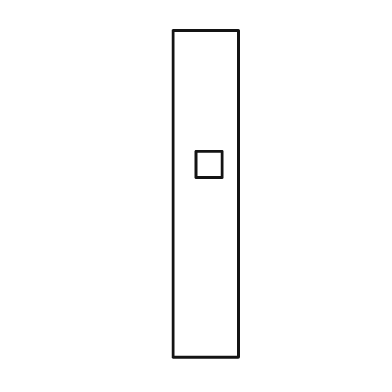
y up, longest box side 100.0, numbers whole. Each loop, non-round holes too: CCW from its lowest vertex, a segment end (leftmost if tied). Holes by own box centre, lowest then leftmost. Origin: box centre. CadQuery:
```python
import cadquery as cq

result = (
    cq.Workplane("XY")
    .moveTo(-10.0, -50.0)
    .lineTo(10.0, -50.0)
    .lineTo(10.0, 50.0)
    .lineTo(-10.0, 50.0)
    .close()
    .moveTo(-3.0, 5.0)
    .lineTo(5.0, 5.0)
    .lineTo(5.0, 13.0)
    .lineTo(-3.0, 13.0)
    .close()
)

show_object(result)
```